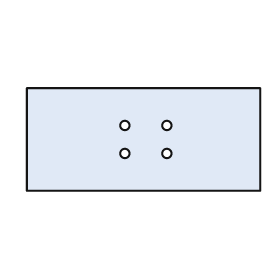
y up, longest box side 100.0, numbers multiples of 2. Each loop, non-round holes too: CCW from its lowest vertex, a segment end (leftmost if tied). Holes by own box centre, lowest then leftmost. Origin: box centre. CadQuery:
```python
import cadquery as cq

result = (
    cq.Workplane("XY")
    .moveTo(-50.0, -22.0)
    .lineTo(50.0, -22.0)
    .lineTo(50.0, 22.0)
    .lineTo(-50.0, 22.0)
    .close()
    .moveTo(-8.0, -6.0)
    .circle(2.0)
    .moveTo(10.0, -6.0)
    .circle(2.0)
    .moveTo(-8.0, 6.0)
    .circle(2.0)
    .moveTo(10.0, 6.0)
    .circle(2.0)
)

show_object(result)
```